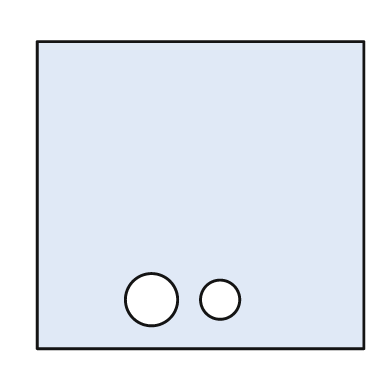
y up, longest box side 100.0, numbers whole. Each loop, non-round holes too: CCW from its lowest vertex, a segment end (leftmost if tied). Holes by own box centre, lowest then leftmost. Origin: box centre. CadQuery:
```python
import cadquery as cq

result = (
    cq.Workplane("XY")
    .moveTo(-50.0, -47.0)
    .lineTo(50.0, -47.0)
    .lineTo(50.0, 47.0)
    .lineTo(-50.0, 47.0)
    .close()
    .moveTo(-15.0, -32.0)
    .circle(8.0)
    .moveTo(6.0, -32.0)
    .circle(6.0)
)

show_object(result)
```